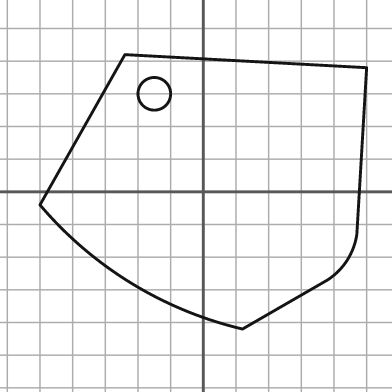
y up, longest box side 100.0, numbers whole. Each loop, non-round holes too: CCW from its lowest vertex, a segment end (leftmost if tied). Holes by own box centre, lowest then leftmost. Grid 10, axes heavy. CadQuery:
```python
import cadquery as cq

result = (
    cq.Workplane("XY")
    .moveTo(12.0, -42.0)
    .lineTo(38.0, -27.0)
    .threePointArc((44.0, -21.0), (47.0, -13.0))
    .lineTo(50.0, 38.0)
    .lineTo(-24.0, 42.0)
    .lineTo(-50.0, -4.0)
    .threePointArc((-22.0, -28.0), (12.0, -42.0))
    .close()
    .moveTo(-15.0, 30.0)
    .circle(5.0)
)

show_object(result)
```